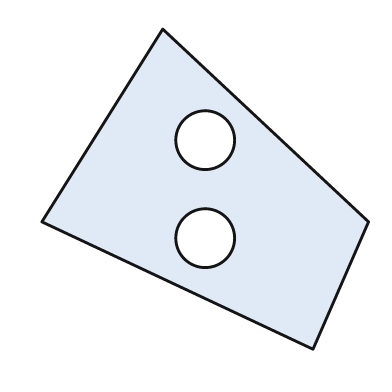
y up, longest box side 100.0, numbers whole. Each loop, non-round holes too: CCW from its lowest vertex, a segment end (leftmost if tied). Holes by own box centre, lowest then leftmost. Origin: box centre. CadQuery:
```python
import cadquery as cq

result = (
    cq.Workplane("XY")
    .moveTo(33.0, -49.0)
    .lineTo(50.0, -10.0)
    .lineTo(-13.0, 49.0)
    .lineTo(-50.0, -10.0)
    .close()
    .moveTo(0.0, -15.0)
    .circle(9.0)
    .moveTo(0.0, 15.0)
    .circle(9.0)
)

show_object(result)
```